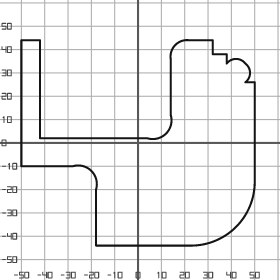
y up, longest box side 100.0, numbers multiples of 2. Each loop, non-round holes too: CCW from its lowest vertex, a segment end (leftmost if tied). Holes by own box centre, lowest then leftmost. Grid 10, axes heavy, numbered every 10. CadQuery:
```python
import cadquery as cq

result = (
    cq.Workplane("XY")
    .moveTo(-18.0, -44.0)
    .lineTo(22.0, -44.0)
    .threePointArc((42.0, -36.0), (50.0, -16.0))
    .lineTo(50.0, 26.0)
    .lineTo(46.0, 26.0)
    .threePointArc((48.0, 30.0), (46.0, 34.0))
    .threePointArc((42.0, 36.0), (38.0, 34.0))
    .lineTo(38.0, 38.0)
    .lineTo(32.0, 38.0)
    .lineTo(32.0, 44.0)
    .lineTo(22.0, 44.0)
    .threePointArc((16.0, 42.0), (14.0, 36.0))
    .lineTo(14.0, 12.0)
    .threePointArc((12.0, 4.0), (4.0, 2.0))
    .lineTo(-42.0, 2.0)
    .lineTo(-42.0, 44.0)
    .lineTo(-50.0, 44.0)
    .lineTo(-50.0, -10.0)
    .lineTo(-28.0, -10.0)
    .threePointArc((-20.0, -12.0), (-18.0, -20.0))
    .close()
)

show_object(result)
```